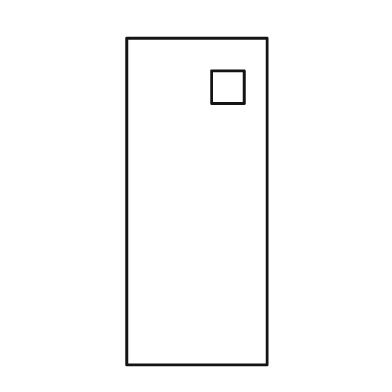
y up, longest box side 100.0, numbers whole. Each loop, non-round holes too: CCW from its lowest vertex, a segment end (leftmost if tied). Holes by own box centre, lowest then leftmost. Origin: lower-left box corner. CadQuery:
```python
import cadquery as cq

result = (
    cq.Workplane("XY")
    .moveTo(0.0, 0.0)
    .lineTo(43.0, 0.0)
    .lineTo(43.0, 100.0)
    .lineTo(0.0, 100.0)
    .close()
    .moveTo(26.0, 80.0)
    .lineTo(36.0, 80.0)
    .lineTo(36.0, 90.0)
    .lineTo(26.0, 90.0)
    .close()
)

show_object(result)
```